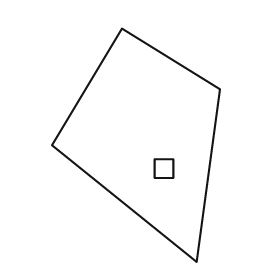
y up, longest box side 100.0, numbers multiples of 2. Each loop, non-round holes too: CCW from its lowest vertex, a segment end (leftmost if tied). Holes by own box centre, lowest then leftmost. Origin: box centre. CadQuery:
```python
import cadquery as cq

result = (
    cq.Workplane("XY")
    .moveTo(26.0, -50.0)
    .lineTo(36.0, 24.0)
    .lineTo(-6.0, 50.0)
    .lineTo(-36.0, 0.0)
    .close()
    .moveTo(8.0, -14.0)
    .lineTo(16.0, -14.0)
    .lineTo(16.0, -6.0)
    .lineTo(8.0, -6.0)
    .close()
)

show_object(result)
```